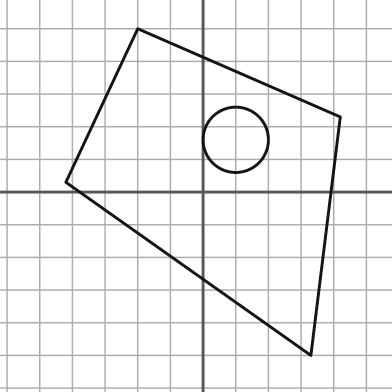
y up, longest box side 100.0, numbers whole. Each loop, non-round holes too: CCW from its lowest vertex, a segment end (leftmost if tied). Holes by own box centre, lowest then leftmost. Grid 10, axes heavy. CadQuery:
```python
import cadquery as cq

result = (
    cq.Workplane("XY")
    .moveTo(33.0, -50.0)
    .lineTo(42.0, 23.0)
    .lineTo(-20.0, 50.0)
    .lineTo(-42.0, 3.0)
    .close()
    .moveTo(10.0, 16.0)
    .circle(10.0)
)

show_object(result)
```